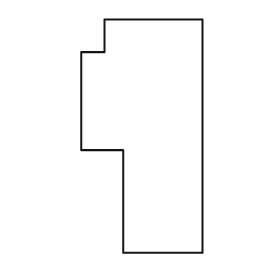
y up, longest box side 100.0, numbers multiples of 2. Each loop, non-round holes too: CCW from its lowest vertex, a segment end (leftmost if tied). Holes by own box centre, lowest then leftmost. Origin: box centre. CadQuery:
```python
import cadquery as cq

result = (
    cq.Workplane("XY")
    .moveTo(-8.0, -50.0)
    .lineTo(26.0, -50.0)
    .lineTo(26.0, 50.0)
    .lineTo(-16.0, 50.0)
    .lineTo(-16.0, 36.0)
    .lineTo(-26.0, 36.0)
    .lineTo(-26.0, -6.0)
    .lineTo(-8.0, -6.0)
    .close()
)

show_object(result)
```